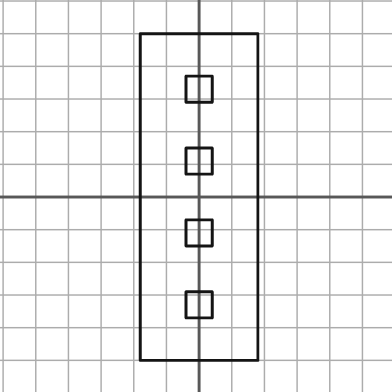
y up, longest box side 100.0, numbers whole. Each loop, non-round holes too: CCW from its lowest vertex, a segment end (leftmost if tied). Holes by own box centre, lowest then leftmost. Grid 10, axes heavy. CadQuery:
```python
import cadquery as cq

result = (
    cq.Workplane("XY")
    .moveTo(-18.0, -50.0)
    .lineTo(18.0, -50.0)
    .lineTo(18.0, 50.0)
    .lineTo(-18.0, 50.0)
    .close()
    .moveTo(-4.0, -37.0)
    .lineTo(4.0, -37.0)
    .lineTo(4.0, -29.0)
    .lineTo(-4.0, -29.0)
    .close()
    .moveTo(-4.0, -15.0)
    .lineTo(4.0, -15.0)
    .lineTo(4.0, -7.0)
    .lineTo(-4.0, -7.0)
    .close()
    .moveTo(-4.0, 7.0)
    .lineTo(4.0, 7.0)
    .lineTo(4.0, 15.0)
    .lineTo(-4.0, 15.0)
    .close()
    .moveTo(-4.0, 29.0)
    .lineTo(4.0, 29.0)
    .lineTo(4.0, 37.0)
    .lineTo(-4.0, 37.0)
    .close()
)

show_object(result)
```